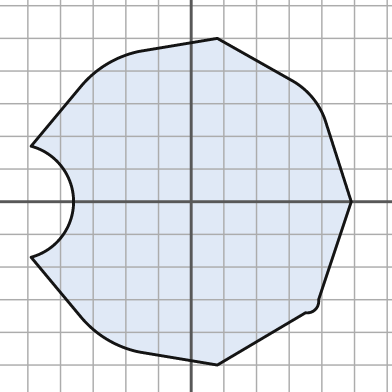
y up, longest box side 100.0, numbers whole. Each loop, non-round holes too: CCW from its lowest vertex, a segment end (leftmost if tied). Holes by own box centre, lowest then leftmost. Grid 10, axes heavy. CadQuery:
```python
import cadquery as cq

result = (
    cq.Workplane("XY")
    .moveTo(8.0, -50.0)
    .lineTo(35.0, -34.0)
    .threePointArc((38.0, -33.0), (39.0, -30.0))
    .lineTo(49.0, 0.0)
    .lineTo(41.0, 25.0)
    .threePointArc((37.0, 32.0), (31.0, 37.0))
    .lineTo(8.0, 50.0)
    .lineTo(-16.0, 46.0)
    .threePointArc((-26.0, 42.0), (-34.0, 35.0))
    .lineTo(-49.0, 17.0)
    .threePointArc((-36.0, 0.0), (-49.0, -17.0))
    .lineTo(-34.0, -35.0)
    .threePointArc((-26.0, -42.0), (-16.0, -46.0))
    .close()
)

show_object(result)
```